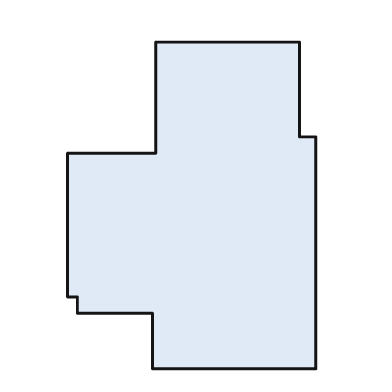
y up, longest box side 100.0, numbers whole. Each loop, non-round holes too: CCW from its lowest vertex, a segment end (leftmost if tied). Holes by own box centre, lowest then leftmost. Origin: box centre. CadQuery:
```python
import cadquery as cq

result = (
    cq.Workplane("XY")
    .moveTo(-12.0, -50.0)
    .lineTo(38.0, -50.0)
    .lineTo(38.0, 21.0)
    .lineTo(33.0, 21.0)
    .lineTo(33.0, 50.0)
    .lineTo(-11.0, 50.0)
    .lineTo(-11.0, 16.0)
    .lineTo(-38.0, 16.0)
    .lineTo(-38.0, -28.0)
    .lineTo(-35.0, -28.0)
    .lineTo(-35.0, -33.0)
    .lineTo(-12.0, -33.0)
    .close()
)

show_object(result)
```